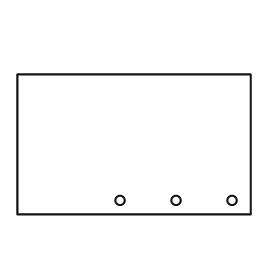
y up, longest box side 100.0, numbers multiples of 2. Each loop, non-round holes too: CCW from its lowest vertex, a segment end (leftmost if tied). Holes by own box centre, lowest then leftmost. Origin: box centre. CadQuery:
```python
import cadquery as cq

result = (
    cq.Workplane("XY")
    .moveTo(-50.0, -30.0)
    .lineTo(50.0, -30.0)
    .lineTo(50.0, 30.0)
    .lineTo(-50.0, 30.0)
    .close()
    .moveTo(-6.0, -24.0)
    .circle(2.0)
    .moveTo(18.0, -24.0)
    .circle(2.0)
    .moveTo(42.0, -24.0)
    .circle(2.0)
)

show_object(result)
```